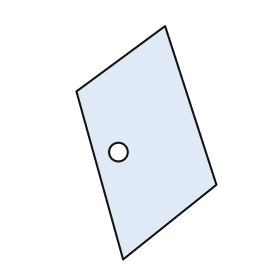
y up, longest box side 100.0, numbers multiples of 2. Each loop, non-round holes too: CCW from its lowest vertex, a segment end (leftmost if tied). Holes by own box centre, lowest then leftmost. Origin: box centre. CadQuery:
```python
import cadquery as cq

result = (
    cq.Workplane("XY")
    .moveTo(-10.0, -50.0)
    .lineTo(30.0, -18.0)
    .lineTo(8.0, 50.0)
    .lineTo(-30.0, 22.0)
    .close()
    .moveTo(-12.0, -4.0)
    .circle(4.0)
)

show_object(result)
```